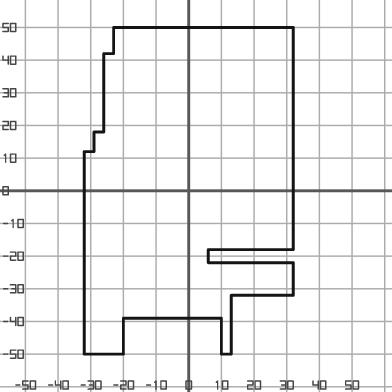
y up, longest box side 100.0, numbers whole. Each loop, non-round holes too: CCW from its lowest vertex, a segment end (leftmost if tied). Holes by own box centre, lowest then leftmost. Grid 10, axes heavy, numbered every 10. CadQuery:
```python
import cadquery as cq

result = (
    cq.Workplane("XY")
    .moveTo(-32.0, -50.0)
    .lineTo(-20.0, -50.0)
    .lineTo(-20.0, -39.0)
    .lineTo(10.0, -39.0)
    .lineTo(10.0, -50.0)
    .lineTo(13.0, -50.0)
    .lineTo(13.0, -32.0)
    .lineTo(32.0, -32.0)
    .lineTo(32.0, -22.0)
    .lineTo(6.0, -22.0)
    .lineTo(6.0, -18.0)
    .lineTo(32.0, -18.0)
    .lineTo(32.0, 50.0)
    .lineTo(-23.0, 50.0)
    .lineTo(-23.0, 42.0)
    .lineTo(-26.0, 42.0)
    .lineTo(-26.0, 18.0)
    .lineTo(-29.0, 18.0)
    .lineTo(-29.0, 12.0)
    .lineTo(-32.0, 12.0)
    .close()
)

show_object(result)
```